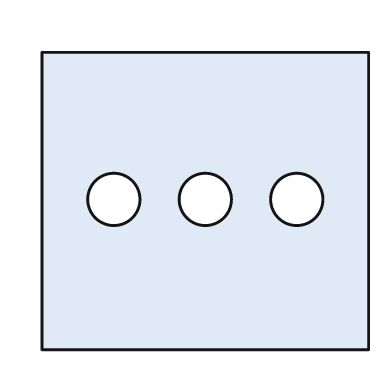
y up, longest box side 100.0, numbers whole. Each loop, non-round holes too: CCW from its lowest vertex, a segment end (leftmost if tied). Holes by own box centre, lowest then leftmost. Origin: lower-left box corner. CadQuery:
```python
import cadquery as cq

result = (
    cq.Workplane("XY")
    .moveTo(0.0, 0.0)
    .lineTo(100.0, 0.0)
    .lineTo(100.0, 91.0)
    .lineTo(0.0, 91.0)
    .close()
    .moveTo(22.0, 46.0)
    .circle(8.0)
    .moveTo(50.0, 46.0)
    .circle(8.0)
    .moveTo(78.0, 46.0)
    .circle(8.0)
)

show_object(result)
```